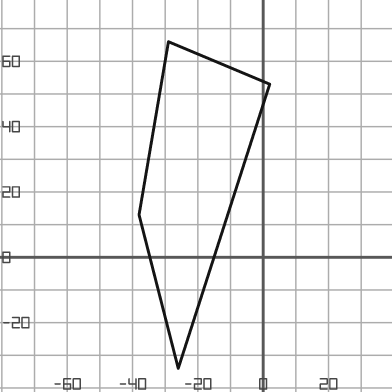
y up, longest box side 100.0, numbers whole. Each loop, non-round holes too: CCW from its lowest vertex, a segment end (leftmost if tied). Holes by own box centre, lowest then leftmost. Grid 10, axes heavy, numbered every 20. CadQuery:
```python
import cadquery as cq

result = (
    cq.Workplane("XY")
    .moveTo(-26.0, -34.0)
    .lineTo(2.0, 53.0)
    .lineTo(-29.0, 66.0)
    .lineTo(-38.0, 13.0)
    .close()
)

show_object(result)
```